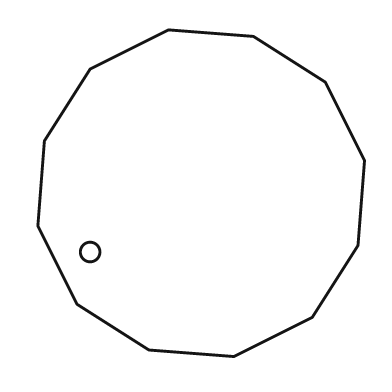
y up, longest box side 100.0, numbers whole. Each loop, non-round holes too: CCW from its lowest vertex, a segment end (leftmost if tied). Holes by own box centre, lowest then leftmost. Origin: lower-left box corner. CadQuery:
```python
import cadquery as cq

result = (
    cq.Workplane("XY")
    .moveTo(60.0, 0.0)
    .lineTo(84.0, 12.0)
    .lineTo(98.0, 34.0)
    .lineTo(100.0, 60.0)
    .lineTo(88.0, 84.0)
    .lineTo(66.0, 98.0)
    .lineTo(40.0, 100.0)
    .lineTo(16.0, 88.0)
    .lineTo(2.0, 66.0)
    .lineTo(0.0, 40.0)
    .lineTo(12.0, 16.0)
    .lineTo(34.0, 2.0)
    .close()
    .moveTo(16.0, 32.0)
    .circle(3.0)
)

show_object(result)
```